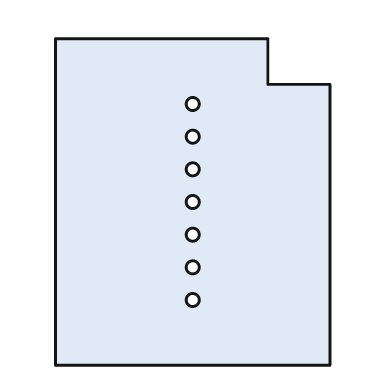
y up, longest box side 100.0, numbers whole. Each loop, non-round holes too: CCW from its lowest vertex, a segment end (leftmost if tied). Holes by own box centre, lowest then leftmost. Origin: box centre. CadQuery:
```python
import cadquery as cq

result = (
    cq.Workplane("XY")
    .moveTo(-42.0, -50.0)
    .lineTo(42.0, -50.0)
    .lineTo(42.0, 36.0)
    .lineTo(23.0, 36.0)
    .lineTo(23.0, 50.0)
    .lineTo(-42.0, 50.0)
    .close()
    .moveTo(0.0, -30.0)
    .circle(2.0)
    .moveTo(0.0, -20.0)
    .circle(2.0)
    .moveTo(0.0, -10.0)
    .circle(2.0)
    .moveTo(0.0, 0.0)
    .circle(2.0)
    .moveTo(0.0, 10.0)
    .circle(2.0)
    .moveTo(0.0, 20.0)
    .circle(2.0)
    .moveTo(0.0, 30.0)
    .circle(2.0)
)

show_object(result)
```